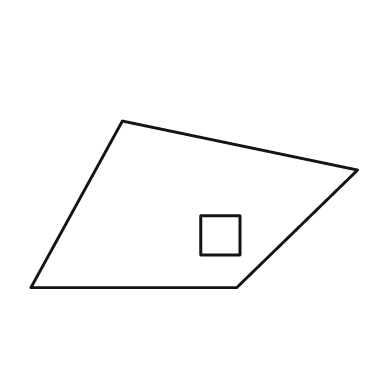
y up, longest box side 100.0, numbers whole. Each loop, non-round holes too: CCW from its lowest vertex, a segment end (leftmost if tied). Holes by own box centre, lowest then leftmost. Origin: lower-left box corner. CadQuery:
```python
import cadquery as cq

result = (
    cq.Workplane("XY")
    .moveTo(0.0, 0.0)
    .lineTo(63.0, 0.0)
    .lineTo(100.0, 36.0)
    .lineTo(28.0, 51.0)
    .close()
    .moveTo(52.0, 10.0)
    .lineTo(64.0, 10.0)
    .lineTo(64.0, 22.0)
    .lineTo(52.0, 22.0)
    .close()
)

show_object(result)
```